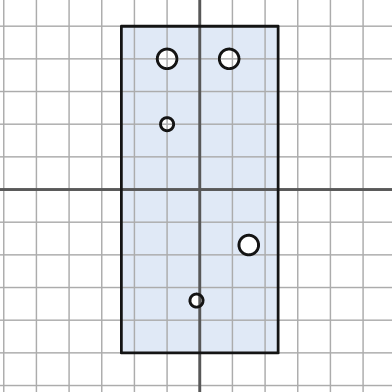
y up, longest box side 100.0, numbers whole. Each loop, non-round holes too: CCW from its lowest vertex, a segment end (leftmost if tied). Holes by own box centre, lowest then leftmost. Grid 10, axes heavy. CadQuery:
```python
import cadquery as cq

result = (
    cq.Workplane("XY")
    .moveTo(-24.0, -50.0)
    .lineTo(24.0, -50.0)
    .lineTo(24.0, 50.0)
    .lineTo(-24.0, 50.0)
    .close()
    .moveTo(-1.0, -34.0)
    .circle(2.0)
    .moveTo(15.0, -17.0)
    .circle(3.0)
    .moveTo(-10.0, 20.0)
    .circle(2.0)
    .moveTo(-10.0, 40.0)
    .circle(3.0)
    .moveTo(9.0, 40.0)
    .circle(3.0)
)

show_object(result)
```